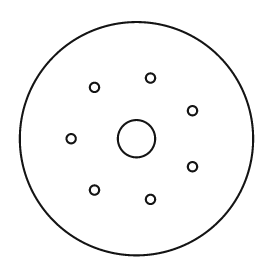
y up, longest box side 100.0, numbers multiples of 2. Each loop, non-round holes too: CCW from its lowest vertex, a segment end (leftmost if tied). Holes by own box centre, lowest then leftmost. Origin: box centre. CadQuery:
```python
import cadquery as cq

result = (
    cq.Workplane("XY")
    .moveTo(0.0, 0.0)
    .circle(50.0)
    .moveTo(6.0, -26.0)
    .circle(2.0)
    .moveTo(-18.0, -22.0)
    .circle(2.0)
    .moveTo(24.0, -12.0)
    .circle(2.0)
    .moveTo(-28.0, 0.0)
    .circle(2.0)
    .moveTo(0.0, 0.0)
    .circle(8.0)
    .moveTo(24.0, 12.0)
    .circle(2.0)
    .moveTo(-18.0, 22.0)
    .circle(2.0)
    .moveTo(6.0, 26.0)
    .circle(2.0)
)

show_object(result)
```